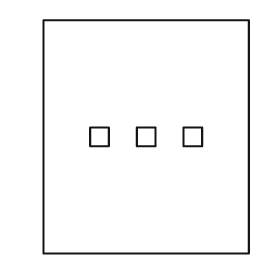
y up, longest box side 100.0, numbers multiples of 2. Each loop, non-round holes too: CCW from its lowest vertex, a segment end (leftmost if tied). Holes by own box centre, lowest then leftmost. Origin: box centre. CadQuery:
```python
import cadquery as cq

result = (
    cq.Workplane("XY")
    .moveTo(-44.0, -50.0)
    .lineTo(44.0, -50.0)
    .lineTo(44.0, 50.0)
    .lineTo(-44.0, 50.0)
    .close()
    .moveTo(-24.0, -4.0)
    .lineTo(-16.0, -4.0)
    .lineTo(-16.0, 4.0)
    .lineTo(-24.0, 4.0)
    .close()
    .moveTo(-4.0, -4.0)
    .lineTo(4.0, -4.0)
    .lineTo(4.0, 4.0)
    .lineTo(-4.0, 4.0)
    .close()
    .moveTo(16.0, -4.0)
    .lineTo(24.0, -4.0)
    .lineTo(24.0, 4.0)
    .lineTo(16.0, 4.0)
    .close()
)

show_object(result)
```